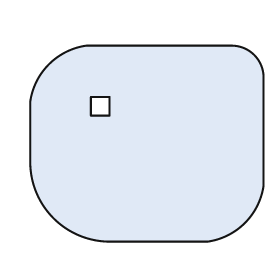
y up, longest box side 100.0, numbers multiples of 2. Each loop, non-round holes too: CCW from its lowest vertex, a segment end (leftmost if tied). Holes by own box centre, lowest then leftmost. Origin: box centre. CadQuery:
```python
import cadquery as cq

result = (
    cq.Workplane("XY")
    .moveTo(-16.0, -42.0)
    .lineTo(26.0, -42.0)
    .threePointArc((42.0, -34.0), (50.0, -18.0))
    .lineTo(50.0, 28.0)
    .threePointArc((46.0, 38.0), (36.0, 42.0))
    .lineTo(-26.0, 42.0)
    .threePointArc((-42.0, 34.0), (-50.0, 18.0))
    .lineTo(-50.0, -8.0)
    .threePointArc((-40.0, -32.0), (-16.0, -42.0))
    .close()
    .moveTo(-24.0, 12.0)
    .lineTo(-16.0, 12.0)
    .lineTo(-16.0, 20.0)
    .lineTo(-24.0, 20.0)
    .close()
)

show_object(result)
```